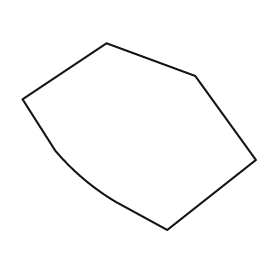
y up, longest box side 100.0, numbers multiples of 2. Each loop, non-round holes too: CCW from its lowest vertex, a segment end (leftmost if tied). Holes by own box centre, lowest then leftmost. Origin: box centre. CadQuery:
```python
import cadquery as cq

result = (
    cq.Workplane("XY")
    .moveTo(12.0, -40.0)
    .lineTo(50.0, -10.0)
    .lineTo(24.0, 26.0)
    .lineTo(-14.0, 40.0)
    .lineTo(-50.0, 16.0)
    .lineTo(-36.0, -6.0)
    .threePointArc((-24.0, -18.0), (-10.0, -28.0))
    .close()
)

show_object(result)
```